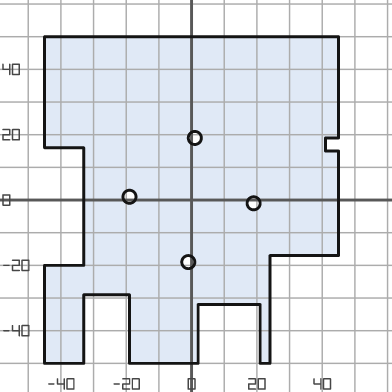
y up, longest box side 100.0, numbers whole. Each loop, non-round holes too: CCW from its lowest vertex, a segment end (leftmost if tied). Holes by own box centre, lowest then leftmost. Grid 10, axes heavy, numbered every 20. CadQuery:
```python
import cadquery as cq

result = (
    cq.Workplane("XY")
    .moveTo(-45.0, -50.0)
    .lineTo(-33.0, -50.0)
    .lineTo(-33.0, -29.0)
    .lineTo(-19.0, -29.0)
    .lineTo(-19.0, -50.0)
    .lineTo(2.0, -50.0)
    .lineTo(2.0, -32.0)
    .lineTo(21.0, -32.0)
    .lineTo(21.0, -50.0)
    .lineTo(24.0, -50.0)
    .lineTo(24.0, -17.0)
    .lineTo(45.0, -17.0)
    .lineTo(45.0, 15.0)
    .lineTo(41.0, 15.0)
    .lineTo(41.0, 19.0)
    .lineTo(45.0, 19.0)
    .lineTo(45.0, 50.0)
    .lineTo(-45.0, 50.0)
    .lineTo(-45.0, 16.0)
    .lineTo(-33.0, 16.0)
    .lineTo(-33.0, -20.0)
    .lineTo(-45.0, -20.0)
    .close()
    .moveTo(-1.0, -19.0)
    .circle(2.0)
    .moveTo(19.0, -1.0)
    .circle(2.0)
    .moveTo(-19.0, 1.0)
    .circle(2.0)
    .moveTo(1.0, 19.0)
    .circle(2.0)
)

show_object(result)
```